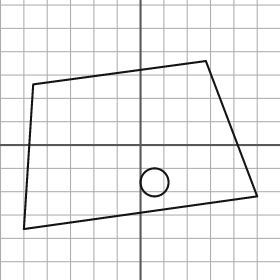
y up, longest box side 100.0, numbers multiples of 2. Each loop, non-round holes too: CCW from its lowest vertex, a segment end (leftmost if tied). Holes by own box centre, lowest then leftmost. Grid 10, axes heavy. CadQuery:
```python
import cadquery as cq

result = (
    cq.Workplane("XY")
    .moveTo(-50.0, -36.0)
    .lineTo(50.0, -22.0)
    .lineTo(28.0, 36.0)
    .lineTo(-46.0, 26.0)
    .close()
    .moveTo(6.0, -16.0)
    .circle(6.0)
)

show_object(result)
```